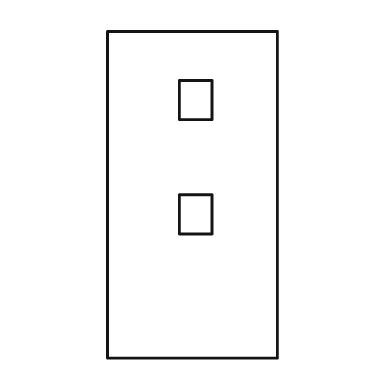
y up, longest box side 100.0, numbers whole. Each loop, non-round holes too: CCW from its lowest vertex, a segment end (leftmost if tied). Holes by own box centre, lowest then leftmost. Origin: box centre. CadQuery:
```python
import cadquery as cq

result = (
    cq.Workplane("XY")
    .moveTo(-26.0, -50.0)
    .lineTo(26.0, -50.0)
    .lineTo(26.0, 50.0)
    .lineTo(-26.0, 50.0)
    .close()
    .moveTo(-4.0, -12.0)
    .lineTo(6.0, -12.0)
    .lineTo(6.0, 0.0)
    .lineTo(-4.0, 0.0)
    .close()
    .moveTo(-4.0, 23.0)
    .lineTo(6.0, 23.0)
    .lineTo(6.0, 35.0)
    .lineTo(-4.0, 35.0)
    .close()
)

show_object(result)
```